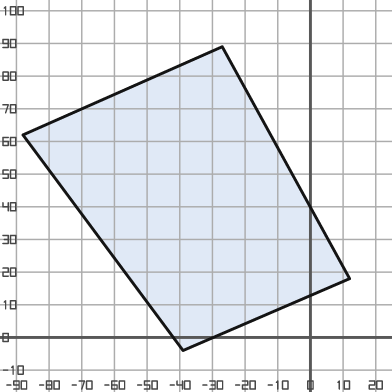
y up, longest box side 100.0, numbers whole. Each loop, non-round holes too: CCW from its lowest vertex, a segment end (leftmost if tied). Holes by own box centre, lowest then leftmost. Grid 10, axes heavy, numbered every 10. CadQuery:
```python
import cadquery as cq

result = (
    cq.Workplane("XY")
    .moveTo(-39.0, -4.0)
    .lineTo(12.0, 18.0)
    .lineTo(-27.0, 89.0)
    .lineTo(-88.0, 62.0)
    .close()
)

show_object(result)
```